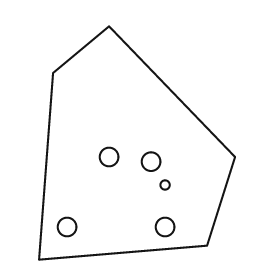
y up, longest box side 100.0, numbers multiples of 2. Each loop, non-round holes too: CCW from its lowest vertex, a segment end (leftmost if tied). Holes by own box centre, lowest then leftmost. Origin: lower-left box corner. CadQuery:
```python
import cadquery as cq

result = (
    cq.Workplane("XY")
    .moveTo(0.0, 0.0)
    .lineTo(72.0, 6.0)
    .lineTo(84.0, 44.0)
    .lineTo(30.0, 100.0)
    .lineTo(6.0, 80.0)
    .close()
    .moveTo(12.0, 14.0)
    .circle(4.0)
    .moveTo(54.0, 14.0)
    .circle(4.0)
    .moveTo(54.0, 32.0)
    .circle(2.0)
    .moveTo(48.0, 42.0)
    .circle(4.0)
    .moveTo(30.0, 44.0)
    .circle(4.0)
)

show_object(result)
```